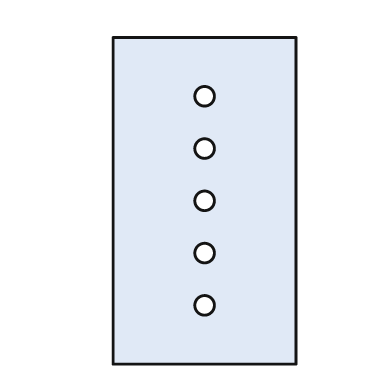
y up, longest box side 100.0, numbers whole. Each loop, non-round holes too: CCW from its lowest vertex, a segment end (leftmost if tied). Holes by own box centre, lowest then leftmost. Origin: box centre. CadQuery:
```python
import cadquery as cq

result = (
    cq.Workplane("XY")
    .moveTo(-28.0, -50.0)
    .lineTo(28.0, -50.0)
    .lineTo(28.0, 50.0)
    .lineTo(-28.0, 50.0)
    .close()
    .moveTo(0.0, -32.0)
    .circle(3.0)
    .moveTo(0.0, -16.0)
    .circle(3.0)
    .moveTo(0.0, 0.0)
    .circle(3.0)
    .moveTo(0.0, 16.0)
    .circle(3.0)
    .moveTo(0.0, 32.0)
    .circle(3.0)
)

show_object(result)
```